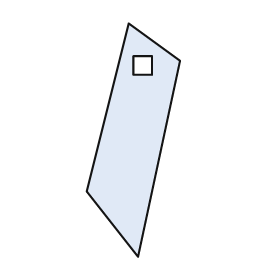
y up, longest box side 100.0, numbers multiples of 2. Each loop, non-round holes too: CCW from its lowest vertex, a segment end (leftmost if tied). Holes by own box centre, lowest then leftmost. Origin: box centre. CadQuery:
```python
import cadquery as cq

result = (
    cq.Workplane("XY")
    .moveTo(2.0, -50.0)
    .lineTo(20.0, 34.0)
    .lineTo(-2.0, 50.0)
    .lineTo(-20.0, -22.0)
    .close()
    .moveTo(0.0, 28.0)
    .lineTo(8.0, 28.0)
    .lineTo(8.0, 36.0)
    .lineTo(0.0, 36.0)
    .close()
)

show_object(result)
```